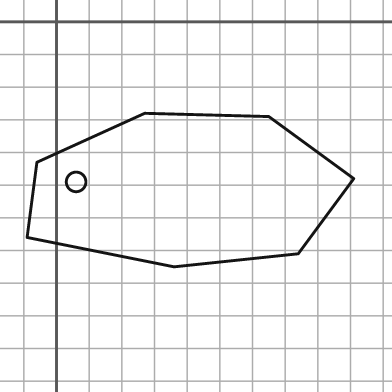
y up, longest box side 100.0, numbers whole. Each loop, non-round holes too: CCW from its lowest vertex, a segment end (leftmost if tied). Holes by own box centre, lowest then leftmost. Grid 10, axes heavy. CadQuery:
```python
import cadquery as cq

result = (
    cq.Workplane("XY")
    .moveTo(36.0, -75.0)
    .lineTo(74.0, -71.0)
    .lineTo(91.0, -48.0)
    .lineTo(65.0, -29.0)
    .lineTo(27.0, -28.0)
    .lineTo(-6.0, -43.0)
    .lineTo(-9.0, -66.0)
    .close()
    .moveTo(6.0, -49.0)
    .circle(3.0)
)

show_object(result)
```